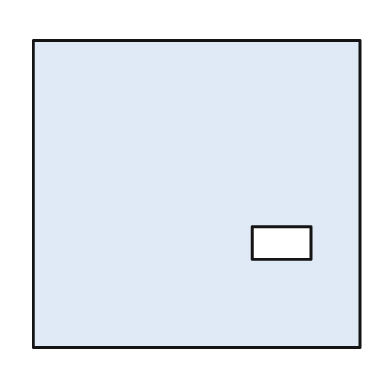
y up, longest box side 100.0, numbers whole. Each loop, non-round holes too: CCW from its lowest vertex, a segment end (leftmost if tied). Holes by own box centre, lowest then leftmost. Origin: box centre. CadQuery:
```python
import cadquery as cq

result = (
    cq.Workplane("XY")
    .moveTo(-50.0, -47.0)
    .lineTo(50.0, -47.0)
    .lineTo(50.0, 47.0)
    .lineTo(-50.0, 47.0)
    .close()
    .moveTo(17.0, -20.0)
    .lineTo(35.0, -20.0)
    .lineTo(35.0, -10.0)
    .lineTo(17.0, -10.0)
    .close()
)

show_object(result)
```